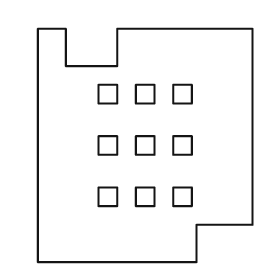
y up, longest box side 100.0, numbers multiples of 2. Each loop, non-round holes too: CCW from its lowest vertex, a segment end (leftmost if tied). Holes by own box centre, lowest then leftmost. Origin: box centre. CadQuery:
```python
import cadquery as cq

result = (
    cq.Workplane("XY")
    .moveTo(-46.0, -50.0)
    .lineTo(22.0, -50.0)
    .lineTo(22.0, -34.0)
    .lineTo(46.0, -34.0)
    .lineTo(46.0, 50.0)
    .lineTo(-12.0, 50.0)
    .lineTo(-12.0, 34.0)
    .lineTo(-34.0, 34.0)
    .lineTo(-34.0, 50.0)
    .lineTo(-46.0, 50.0)
    .close()
    .moveTo(-20.0, -26.0)
    .lineTo(-12.0, -26.0)
    .lineTo(-12.0, -18.0)
    .lineTo(-20.0, -18.0)
    .close()
    .moveTo(-4.0, -26.0)
    .lineTo(4.0, -26.0)
    .lineTo(4.0, -18.0)
    .lineTo(-4.0, -18.0)
    .close()
    .moveTo(12.0, -26.0)
    .lineTo(20.0, -26.0)
    .lineTo(20.0, -18.0)
    .lineTo(12.0, -18.0)
    .close()
    .moveTo(-20.0, -4.0)
    .lineTo(-12.0, -4.0)
    .lineTo(-12.0, 4.0)
    .lineTo(-20.0, 4.0)
    .close()
    .moveTo(-4.0, -4.0)
    .lineTo(4.0, -4.0)
    .lineTo(4.0, 4.0)
    .lineTo(-4.0, 4.0)
    .close()
    .moveTo(12.0, -4.0)
    .lineTo(20.0, -4.0)
    .lineTo(20.0, 4.0)
    .lineTo(12.0, 4.0)
    .close()
    .moveTo(-20.0, 18.0)
    .lineTo(-12.0, 18.0)
    .lineTo(-12.0, 26.0)
    .lineTo(-20.0, 26.0)
    .close()
    .moveTo(-4.0, 18.0)
    .lineTo(4.0, 18.0)
    .lineTo(4.0, 26.0)
    .lineTo(-4.0, 26.0)
    .close()
    .moveTo(12.0, 18.0)
    .lineTo(20.0, 18.0)
    .lineTo(20.0, 26.0)
    .lineTo(12.0, 26.0)
    .close()
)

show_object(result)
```